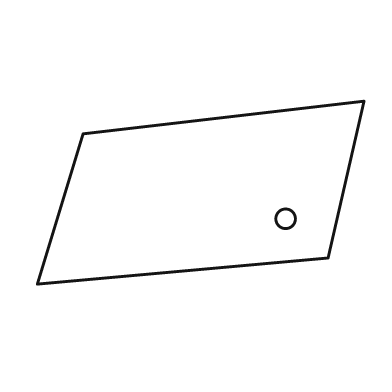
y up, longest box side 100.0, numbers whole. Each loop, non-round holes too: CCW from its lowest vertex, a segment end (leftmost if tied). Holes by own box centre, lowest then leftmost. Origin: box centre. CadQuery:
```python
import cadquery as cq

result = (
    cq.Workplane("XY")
    .moveTo(-50.0, -28.0)
    .lineTo(39.0, -20.0)
    .lineTo(50.0, 28.0)
    .lineTo(-36.0, 18.0)
    .close()
    .moveTo(26.0, -8.0)
    .circle(3.0)
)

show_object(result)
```